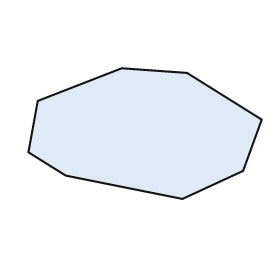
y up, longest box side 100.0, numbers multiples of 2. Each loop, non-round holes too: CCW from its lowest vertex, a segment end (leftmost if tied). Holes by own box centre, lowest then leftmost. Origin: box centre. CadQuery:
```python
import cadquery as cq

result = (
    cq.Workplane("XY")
    .moveTo(16.0, -28.0)
    .lineTo(42.0, -16.0)
    .lineTo(50.0, 6.0)
    .lineTo(18.0, 26.0)
    .lineTo(-10.0, 28.0)
    .lineTo(-46.0, 14.0)
    .lineTo(-50.0, -8.0)
    .lineTo(-34.0, -18.0)
    .close()
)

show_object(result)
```